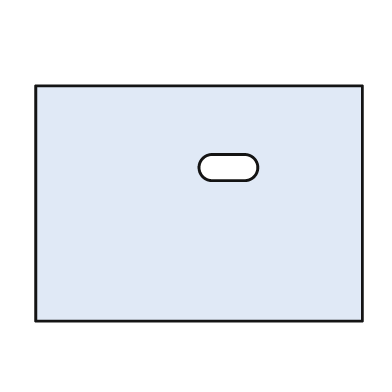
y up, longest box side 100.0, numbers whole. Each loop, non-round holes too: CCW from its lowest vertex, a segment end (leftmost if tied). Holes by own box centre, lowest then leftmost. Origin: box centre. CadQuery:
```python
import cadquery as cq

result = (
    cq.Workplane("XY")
    .moveTo(-50.0, -36.0)
    .lineTo(50.0, -36.0)
    .lineTo(50.0, 36.0)
    .lineTo(-50.0, 36.0)
    .close()
    .moveTo(4.0, 7.0)
    .lineTo(14.0, 7.0)
    .threePointArc((18.0, 11.0), (14.0, 15.0))
    .lineTo(4.0, 15.0)
    .threePointArc((0.0, 11.0), (4.0, 7.0))
    .close()
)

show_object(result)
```